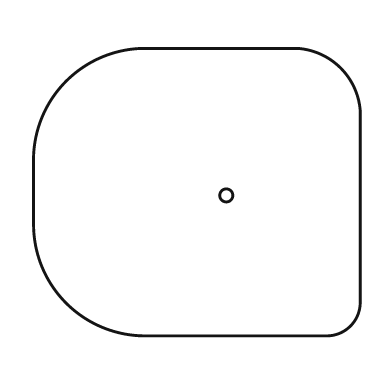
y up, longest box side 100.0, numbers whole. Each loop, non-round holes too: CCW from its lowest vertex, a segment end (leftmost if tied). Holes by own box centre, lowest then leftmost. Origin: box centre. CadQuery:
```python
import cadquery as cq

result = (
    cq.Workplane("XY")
    .moveTo(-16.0, -44.0)
    .lineTo(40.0, -44.0)
    .threePointArc((47.0, -41.0), (50.0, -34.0))
    .lineTo(50.0, 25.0)
    .threePointArc((44.0, 38.0), (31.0, 44.0))
    .lineTo(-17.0, 44.0)
    .threePointArc((-40.0, 34.0), (-50.0, 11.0))
    .lineTo(-50.0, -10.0)
    .threePointArc((-40.0, -34.0), (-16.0, -44.0))
    .close()
    .moveTo(9.0, -1.0)
    .circle(2.0)
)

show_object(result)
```